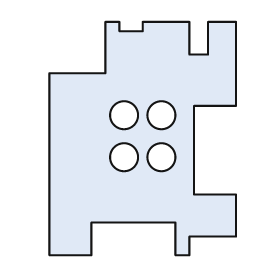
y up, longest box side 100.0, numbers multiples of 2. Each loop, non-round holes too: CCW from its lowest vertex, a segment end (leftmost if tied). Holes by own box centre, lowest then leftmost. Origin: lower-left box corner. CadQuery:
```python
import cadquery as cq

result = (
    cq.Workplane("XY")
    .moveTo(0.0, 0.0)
    .lineTo(18.0, 0.0)
    .lineTo(18.0, 14.0)
    .lineTo(54.0, 14.0)
    .lineTo(54.0, 0.0)
    .lineTo(60.0, 0.0)
    .lineTo(60.0, 8.0)
    .lineTo(80.0, 8.0)
    .lineTo(80.0, 26.0)
    .lineTo(62.0, 26.0)
    .lineTo(62.0, 64.0)
    .lineTo(80.0, 64.0)
    .lineTo(80.0, 100.0)
    .lineTo(68.0, 100.0)
    .lineTo(68.0, 86.0)
    .lineTo(60.0, 86.0)
    .lineTo(60.0, 100.0)
    .lineTo(40.0, 100.0)
    .lineTo(40.0, 96.0)
    .lineTo(30.0, 96.0)
    .lineTo(30.0, 100.0)
    .lineTo(24.0, 100.0)
    .lineTo(24.0, 78.0)
    .lineTo(0.0, 78.0)
    .close()
    .moveTo(32.0, 42.0)
    .circle(6.0)
    .moveTo(48.0, 42.0)
    .circle(6.0)
    .moveTo(32.0, 60.0)
    .circle(6.0)
    .moveTo(48.0, 60.0)
    .circle(6.0)
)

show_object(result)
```